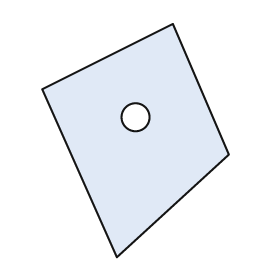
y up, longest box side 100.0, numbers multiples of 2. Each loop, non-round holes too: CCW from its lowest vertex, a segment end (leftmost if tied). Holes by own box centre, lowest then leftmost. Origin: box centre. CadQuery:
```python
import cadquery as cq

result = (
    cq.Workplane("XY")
    .moveTo(-8.0, -50.0)
    .lineTo(40.0, -6.0)
    .lineTo(16.0, 50.0)
    .lineTo(-40.0, 22.0)
    .close()
    .moveTo(0.0, 10.0)
    .circle(6.0)
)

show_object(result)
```